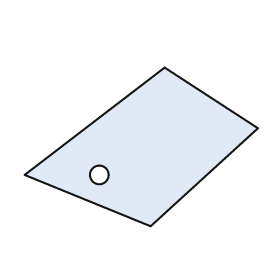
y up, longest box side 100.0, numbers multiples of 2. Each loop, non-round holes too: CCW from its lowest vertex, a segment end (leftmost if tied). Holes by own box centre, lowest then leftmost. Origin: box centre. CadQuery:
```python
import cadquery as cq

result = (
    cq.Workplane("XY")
    .moveTo(4.0, -34.0)
    .lineTo(50.0, 8.0)
    .lineTo(10.0, 34.0)
    .lineTo(-50.0, -12.0)
    .close()
    .moveTo(-18.0, -12.0)
    .circle(4.0)
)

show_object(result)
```